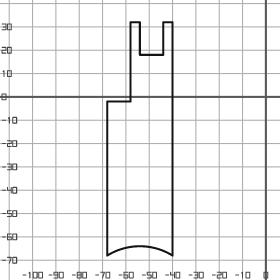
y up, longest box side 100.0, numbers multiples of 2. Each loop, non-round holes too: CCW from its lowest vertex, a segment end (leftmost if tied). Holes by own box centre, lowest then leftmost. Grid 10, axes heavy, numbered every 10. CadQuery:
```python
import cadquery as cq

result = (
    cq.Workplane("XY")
    .moveTo(-68.0, -68.0)
    .threePointArc((-54.0, -64.0), (-40.0, -68.0))
    .lineTo(-40.0, 32.0)
    .lineTo(-44.0, 32.0)
    .lineTo(-44.0, 18.0)
    .lineTo(-54.0, 18.0)
    .lineTo(-54.0, 32.0)
    .lineTo(-58.0, 32.0)
    .lineTo(-58.0, -2.0)
    .lineTo(-68.0, -2.0)
    .close()
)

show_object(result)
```